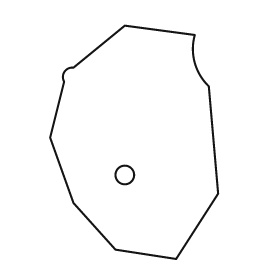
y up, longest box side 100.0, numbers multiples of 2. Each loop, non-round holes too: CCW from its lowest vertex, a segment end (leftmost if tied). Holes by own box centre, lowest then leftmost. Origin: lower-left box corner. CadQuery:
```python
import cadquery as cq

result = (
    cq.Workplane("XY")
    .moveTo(54.0, 0.0)
    .lineTo(72.0, 28.0)
    .lineTo(68.0, 74.0)
    .threePointArc((62.0, 84.0), (62.0, 96.0))
    .lineTo(32.0, 100.0)
    .lineTo(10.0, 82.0)
    .threePointArc((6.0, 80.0), (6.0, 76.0))
    .lineTo(0.0, 52.0)
    .lineTo(10.0, 24.0)
    .lineTo(28.0, 4.0)
    .close()
    .moveTo(32.0, 36.0)
    .circle(4.0)
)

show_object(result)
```